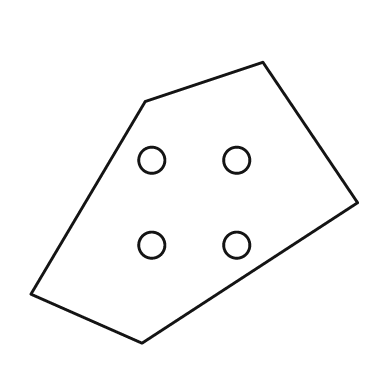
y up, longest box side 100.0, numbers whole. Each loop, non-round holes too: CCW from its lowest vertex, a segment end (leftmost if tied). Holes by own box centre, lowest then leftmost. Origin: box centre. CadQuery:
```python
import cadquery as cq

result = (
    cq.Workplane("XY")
    .moveTo(-16.0, -43.0)
    .lineTo(50.0, 0.0)
    .lineTo(21.0, 43.0)
    .lineTo(-15.0, 31.0)
    .lineTo(-50.0, -28.0)
    .close()
    .moveTo(-13.0, -13.0)
    .circle(4.0)
    .moveTo(13.0, -13.0)
    .circle(4.0)
    .moveTo(-13.0, 13.0)
    .circle(4.0)
    .moveTo(13.0, 13.0)
    .circle(4.0)
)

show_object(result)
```